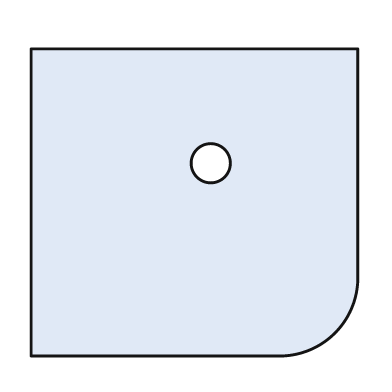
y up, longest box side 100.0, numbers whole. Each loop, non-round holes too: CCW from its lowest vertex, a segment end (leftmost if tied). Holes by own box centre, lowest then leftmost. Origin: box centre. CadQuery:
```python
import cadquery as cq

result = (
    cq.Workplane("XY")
    .moveTo(-50.0, -47.0)
    .lineTo(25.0, -47.0)
    .threePointArc((43.0, -40.0), (50.0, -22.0))
    .lineTo(50.0, 47.0)
    .lineTo(-50.0, 47.0)
    .close()
    .moveTo(5.0, 12.0)
    .circle(6.0)
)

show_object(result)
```